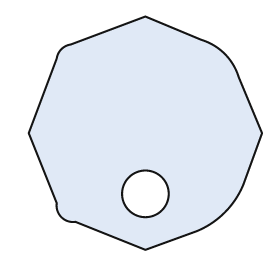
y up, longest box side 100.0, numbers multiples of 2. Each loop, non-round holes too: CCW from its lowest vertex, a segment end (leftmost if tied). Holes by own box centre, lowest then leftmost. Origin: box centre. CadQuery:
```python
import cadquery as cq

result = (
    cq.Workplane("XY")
    .moveTo(0.0, -50.0)
    .lineTo(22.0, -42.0)
    .threePointArc((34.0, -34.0), (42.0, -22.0))
    .lineTo(50.0, 0.0)
    .lineTo(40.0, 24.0)
    .threePointArc((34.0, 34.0), (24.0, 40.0))
    .lineTo(0.0, 50.0)
    .lineTo(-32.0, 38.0)
    .threePointArc((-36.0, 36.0), (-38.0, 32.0))
    .lineTo(-50.0, 0.0)
    .lineTo(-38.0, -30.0)
    .threePointArc((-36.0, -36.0), (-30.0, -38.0))
    .close()
    .moveTo(0.0, -26.0)
    .circle(10.0)
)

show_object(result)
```